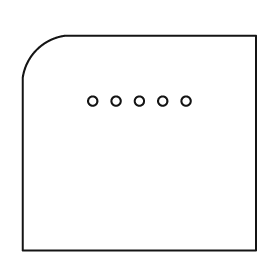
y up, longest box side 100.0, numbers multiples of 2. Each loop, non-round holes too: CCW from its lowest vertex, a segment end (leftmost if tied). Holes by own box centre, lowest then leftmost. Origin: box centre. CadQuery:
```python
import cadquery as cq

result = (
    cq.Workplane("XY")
    .moveTo(-50.0, -46.0)
    .lineTo(50.0, -46.0)
    .lineTo(50.0, 46.0)
    .lineTo(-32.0, 46.0)
    .threePointArc((-44.0, 40.0), (-50.0, 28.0))
    .close()
    .moveTo(-20.0, 18.0)
    .circle(2.0)
    .moveTo(-10.0, 18.0)
    .circle(2.0)
    .moveTo(0.0, 18.0)
    .circle(2.0)
    .moveTo(10.0, 18.0)
    .circle(2.0)
    .moveTo(20.0, 18.0)
    .circle(2.0)
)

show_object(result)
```